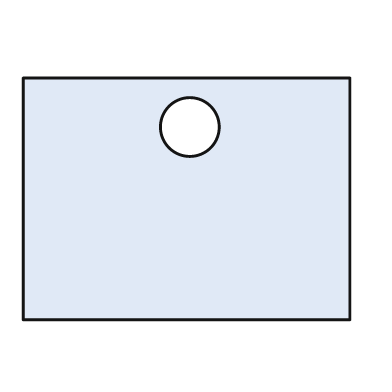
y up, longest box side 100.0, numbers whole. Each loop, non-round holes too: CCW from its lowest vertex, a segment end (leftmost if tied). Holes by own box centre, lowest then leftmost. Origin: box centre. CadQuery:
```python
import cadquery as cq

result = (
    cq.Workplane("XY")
    .moveTo(-50.0, -37.0)
    .lineTo(50.0, -37.0)
    .lineTo(50.0, 37.0)
    .lineTo(-50.0, 37.0)
    .close()
    .moveTo(1.0, 22.0)
    .circle(9.0)
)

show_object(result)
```